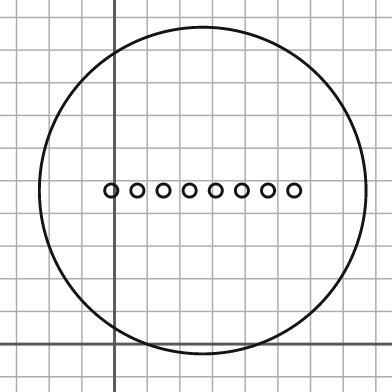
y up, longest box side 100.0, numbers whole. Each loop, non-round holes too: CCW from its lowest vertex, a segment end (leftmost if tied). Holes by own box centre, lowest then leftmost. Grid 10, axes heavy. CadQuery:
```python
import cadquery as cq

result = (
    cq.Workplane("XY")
    .moveTo(27.0, 47.0)
    .circle(50.0)
    .moveTo(-1.0, 47.0)
    .circle(2.0)
    .moveTo(7.0, 47.0)
    .circle(2.0)
    .moveTo(15.0, 47.0)
    .circle(2.0)
    .moveTo(23.0, 47.0)
    .circle(2.0)
    .moveTo(31.0, 47.0)
    .circle(2.0)
    .moveTo(39.0, 47.0)
    .circle(2.0)
    .moveTo(47.0, 47.0)
    .circle(2.0)
    .moveTo(55.0, 47.0)
    .circle(2.0)
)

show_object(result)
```